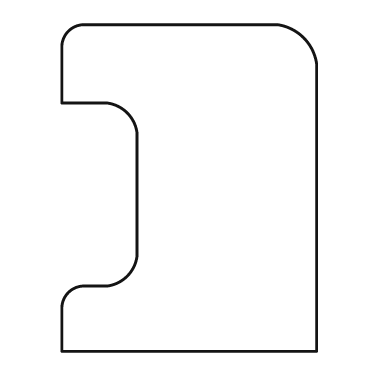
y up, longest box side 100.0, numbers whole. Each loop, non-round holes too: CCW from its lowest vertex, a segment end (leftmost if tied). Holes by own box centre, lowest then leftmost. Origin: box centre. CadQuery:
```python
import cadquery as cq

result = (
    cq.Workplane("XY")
    .moveTo(-39.0, -50.0)
    .lineTo(39.0, -50.0)
    .lineTo(39.0, 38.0)
    .threePointArc((35.0, 46.0), (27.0, 50.0))
    .lineTo(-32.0, 50.0)
    .threePointArc((-37.0, 48.0), (-39.0, 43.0))
    .lineTo(-39.0, 26.0)
    .lineTo(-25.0, 26.0)
    .threePointArc((-19.0, 23.0), (-16.0, 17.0))
    .lineTo(-16.0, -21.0)
    .threePointArc((-19.0, -27.0), (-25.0, -30.0))
    .lineTo(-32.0, -30.0)
    .threePointArc((-37.0, -32.0), (-39.0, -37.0))
    .close()
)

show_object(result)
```